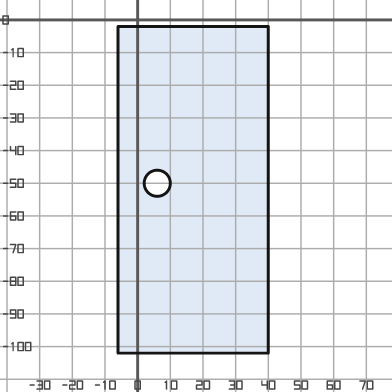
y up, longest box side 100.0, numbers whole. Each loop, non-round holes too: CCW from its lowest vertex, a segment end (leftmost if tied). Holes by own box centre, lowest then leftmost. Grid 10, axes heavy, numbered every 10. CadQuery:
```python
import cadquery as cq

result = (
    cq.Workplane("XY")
    .moveTo(-6.0, -102.0)
    .lineTo(40.0, -102.0)
    .lineTo(40.0, -2.0)
    .lineTo(-6.0, -2.0)
    .close()
    .moveTo(6.0, -50.0)
    .circle(4.0)
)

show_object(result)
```